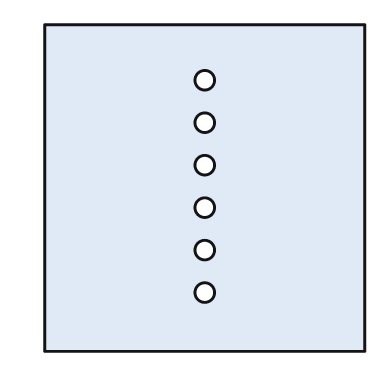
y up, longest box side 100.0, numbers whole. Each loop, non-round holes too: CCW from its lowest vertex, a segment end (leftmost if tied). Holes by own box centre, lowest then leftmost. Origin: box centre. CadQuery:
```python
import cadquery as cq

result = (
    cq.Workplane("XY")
    .moveTo(-49.0, -50.0)
    .lineTo(49.0, -50.0)
    .lineTo(49.0, 50.0)
    .lineTo(-49.0, 50.0)
    .close()
    .moveTo(0.0, -32.0)
    .circle(3.0)
    .moveTo(0.0, -19.0)
    .circle(3.0)
    .moveTo(0.0, -6.0)
    .circle(3.0)
    .moveTo(0.0, 7.0)
    .circle(3.0)
    .moveTo(0.0, 20.0)
    .circle(3.0)
    .moveTo(0.0, 33.0)
    .circle(3.0)
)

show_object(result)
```